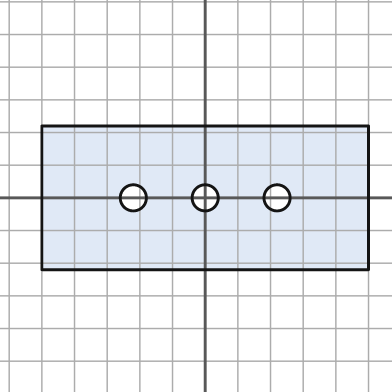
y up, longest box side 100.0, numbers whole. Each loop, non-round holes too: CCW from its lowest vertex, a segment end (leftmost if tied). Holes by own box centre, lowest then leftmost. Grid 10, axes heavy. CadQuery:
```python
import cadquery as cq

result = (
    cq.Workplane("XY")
    .moveTo(-50.0, -22.0)
    .lineTo(50.0, -22.0)
    .lineTo(50.0, 22.0)
    .lineTo(-50.0, 22.0)
    .close()
    .moveTo(-22.0, 0.0)
    .circle(4.0)
    .moveTo(0.0, 0.0)
    .circle(4.0)
    .moveTo(22.0, 0.0)
    .circle(4.0)
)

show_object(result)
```